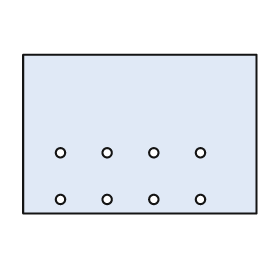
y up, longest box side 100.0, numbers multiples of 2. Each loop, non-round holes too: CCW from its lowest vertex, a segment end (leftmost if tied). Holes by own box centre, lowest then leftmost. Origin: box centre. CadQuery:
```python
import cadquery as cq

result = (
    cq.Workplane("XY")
    .moveTo(-50.0, -34.0)
    .lineTo(50.0, -34.0)
    .lineTo(50.0, 34.0)
    .lineTo(-50.0, 34.0)
    .close()
    .moveTo(-34.0, -28.0)
    .circle(2.0)
    .moveTo(-14.0, -28.0)
    .circle(2.0)
    .moveTo(6.0, -28.0)
    .circle(2.0)
    .moveTo(26.0, -28.0)
    .circle(2.0)
    .moveTo(-34.0, -8.0)
    .circle(2.0)
    .moveTo(-14.0, -8.0)
    .circle(2.0)
    .moveTo(6.0, -8.0)
    .circle(2.0)
    .moveTo(26.0, -8.0)
    .circle(2.0)
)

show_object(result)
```